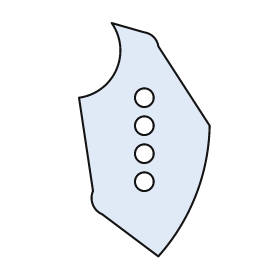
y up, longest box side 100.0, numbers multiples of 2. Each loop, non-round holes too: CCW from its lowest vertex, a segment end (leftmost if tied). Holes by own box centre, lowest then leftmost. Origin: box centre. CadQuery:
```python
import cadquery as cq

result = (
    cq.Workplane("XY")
    .moveTo(6.0, -50.0)
    .threePointArc((22.0, -24.0), (28.0, 6.0))
    .lineTo(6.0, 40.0)
    .threePointArc((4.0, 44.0), (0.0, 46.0))
    .lineTo(-14.0, 50.0)
    .threePointArc((-12.0, 30.0), (-28.0, 18.0))
    .lineTo(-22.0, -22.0)
    .threePointArc((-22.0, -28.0), (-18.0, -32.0))
    .close()
    .moveTo(0.0, -18.0)
    .circle(4.0)
    .moveTo(0.0, -6.0)
    .circle(4.0)
    .moveTo(0.0, 6.0)
    .circle(4.0)
    .moveTo(0.0, 18.0)
    .circle(4.0)
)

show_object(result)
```